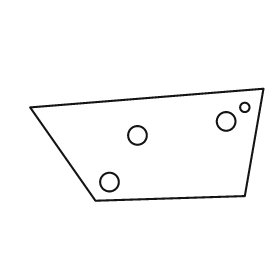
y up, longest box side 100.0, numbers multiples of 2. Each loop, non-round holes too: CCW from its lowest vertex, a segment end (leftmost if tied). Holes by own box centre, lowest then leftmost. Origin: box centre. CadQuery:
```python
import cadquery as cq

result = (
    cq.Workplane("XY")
    .moveTo(-22.0, -24.0)
    .lineTo(42.0, -22.0)
    .lineTo(50.0, 24.0)
    .lineTo(-50.0, 16.0)
    .close()
    .moveTo(-16.0, -16.0)
    .circle(4.0)
    .moveTo(-4.0, 4.0)
    .circle(4.0)
    .moveTo(34.0, 10.0)
    .circle(4.0)
    .moveTo(42.0, 16.0)
    .circle(2.0)
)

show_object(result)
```